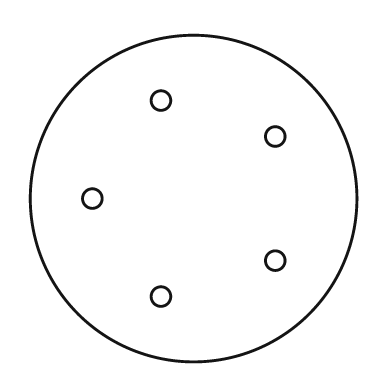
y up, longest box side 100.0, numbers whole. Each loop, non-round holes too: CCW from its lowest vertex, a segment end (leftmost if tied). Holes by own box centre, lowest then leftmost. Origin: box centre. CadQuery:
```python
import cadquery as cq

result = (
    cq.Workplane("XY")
    .moveTo(0.0, 0.0)
    .circle(50.0)
    .moveTo(-10.0, -30.0)
    .circle(3.0)
    .moveTo(25.0, -19.0)
    .circle(3.0)
    .moveTo(-31.0, 0.0)
    .circle(3.0)
    .moveTo(25.0, 19.0)
    .circle(3.0)
    .moveTo(-10.0, 30.0)
    .circle(3.0)
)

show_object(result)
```